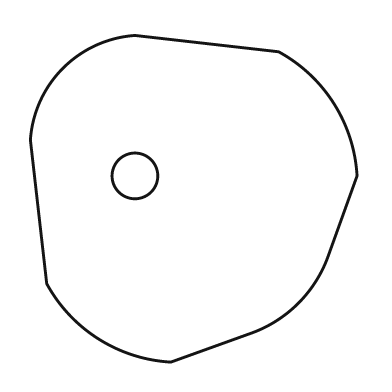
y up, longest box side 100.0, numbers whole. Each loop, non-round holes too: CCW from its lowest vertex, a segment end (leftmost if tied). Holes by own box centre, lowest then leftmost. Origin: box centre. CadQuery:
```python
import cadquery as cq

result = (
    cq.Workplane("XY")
    .moveTo(-7.0, -50.0)
    .lineTo(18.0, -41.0)
    .threePointArc((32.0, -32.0), (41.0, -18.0))
    .lineTo(50.0, 7.0)
    .threePointArc((43.0, 29.0), (26.0, 45.0))
    .lineTo(-18.0, 50.0)
    .threePointArc((-40.0, 40.0), (-50.0, 18.0))
    .lineTo(-45.0, -26.0)
    .threePointArc((-29.0, -43.0), (-7.0, -50.0))
    .close()
    .moveTo(-18.0, 7.0)
    .circle(7.0)
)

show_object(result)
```